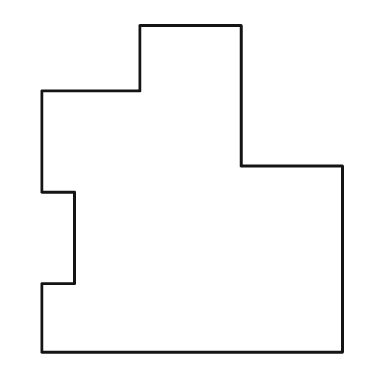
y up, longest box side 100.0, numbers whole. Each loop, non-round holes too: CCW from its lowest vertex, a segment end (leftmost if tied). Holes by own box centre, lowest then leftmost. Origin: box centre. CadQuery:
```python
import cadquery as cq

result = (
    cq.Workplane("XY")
    .moveTo(-46.0, -50.0)
    .lineTo(46.0, -50.0)
    .lineTo(46.0, 7.0)
    .lineTo(15.0, 7.0)
    .lineTo(15.0, 50.0)
    .lineTo(-16.0, 50.0)
    .lineTo(-16.0, 30.0)
    .lineTo(-46.0, 30.0)
    .lineTo(-46.0, -1.0)
    .lineTo(-36.0, -1.0)
    .lineTo(-36.0, -29.0)
    .lineTo(-46.0, -29.0)
    .close()
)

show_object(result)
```